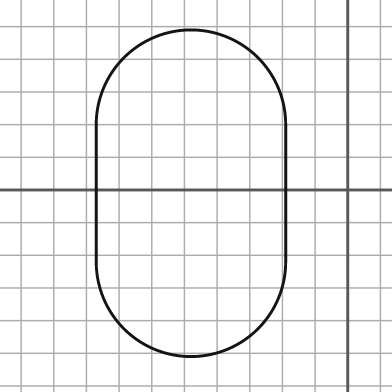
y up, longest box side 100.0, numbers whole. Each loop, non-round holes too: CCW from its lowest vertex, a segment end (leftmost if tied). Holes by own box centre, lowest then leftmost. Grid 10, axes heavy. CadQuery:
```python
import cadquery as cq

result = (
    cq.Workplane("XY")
    .moveTo(-77.0, -22.0)
    .threePointArc((-48.0, -51.0), (-19.0, -22.0))
    .lineTo(-19.0, 20.0)
    .threePointArc((-48.0, 49.0), (-77.0, 20.0))
    .close()
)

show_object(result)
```